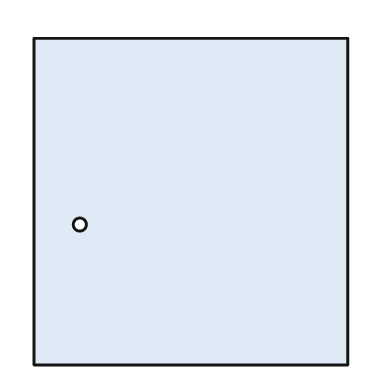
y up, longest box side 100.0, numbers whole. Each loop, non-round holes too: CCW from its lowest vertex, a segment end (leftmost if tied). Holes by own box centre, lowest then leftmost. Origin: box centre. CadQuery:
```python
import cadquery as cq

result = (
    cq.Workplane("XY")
    .moveTo(-48.0, -50.0)
    .lineTo(48.0, -50.0)
    .lineTo(48.0, 50.0)
    .lineTo(-48.0, 50.0)
    .close()
    .moveTo(-34.0, -7.0)
    .circle(2.0)
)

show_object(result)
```